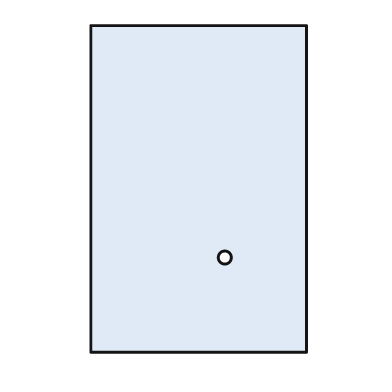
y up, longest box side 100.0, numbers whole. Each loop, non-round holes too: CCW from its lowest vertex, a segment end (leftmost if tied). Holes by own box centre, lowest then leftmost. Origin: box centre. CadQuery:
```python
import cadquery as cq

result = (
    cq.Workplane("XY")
    .moveTo(-33.0, -50.0)
    .lineTo(33.0, -50.0)
    .lineTo(33.0, 50.0)
    .lineTo(-33.0, 50.0)
    .close()
    .moveTo(8.0, -21.0)
    .circle(2.0)
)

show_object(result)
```